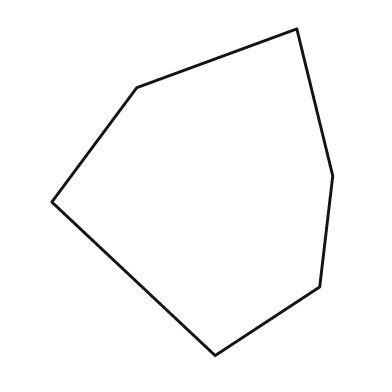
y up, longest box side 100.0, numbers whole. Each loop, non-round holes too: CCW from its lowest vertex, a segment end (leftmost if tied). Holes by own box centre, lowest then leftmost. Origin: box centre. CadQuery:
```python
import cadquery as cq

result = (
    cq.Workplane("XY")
    .moveTo(7.0, -50.0)
    .lineTo(39.0, -29.0)
    .lineTo(43.0, 5.0)
    .lineTo(32.0, 50.0)
    .lineTo(-17.0, 32.0)
    .lineTo(-43.0, -3.0)
    .close()
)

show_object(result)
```